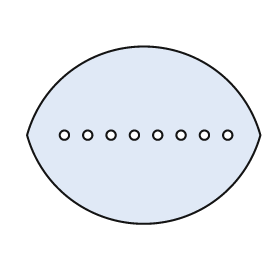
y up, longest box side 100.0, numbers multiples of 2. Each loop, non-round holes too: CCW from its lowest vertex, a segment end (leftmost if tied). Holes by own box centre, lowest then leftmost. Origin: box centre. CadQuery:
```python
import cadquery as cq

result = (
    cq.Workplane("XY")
    .moveTo(-50.0, 0.0)
    .threePointArc((0.0, -38.0), (50.0, 0.0))
    .threePointArc((0.0, 38.0), (-50.0, 0.0))
    .close()
    .moveTo(-34.0, 0.0)
    .circle(2.0)
    .moveTo(-24.0, 0.0)
    .circle(2.0)
    .moveTo(-14.0, 0.0)
    .circle(2.0)
    .moveTo(-4.0, 0.0)
    .circle(2.0)
    .moveTo(6.0, 0.0)
    .circle(2.0)
    .moveTo(16.0, 0.0)
    .circle(2.0)
    .moveTo(26.0, 0.0)
    .circle(2.0)
    .moveTo(36.0, 0.0)
    .circle(2.0)
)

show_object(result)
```